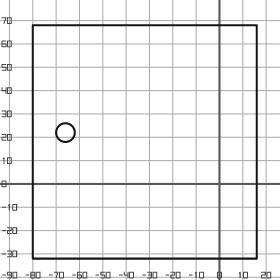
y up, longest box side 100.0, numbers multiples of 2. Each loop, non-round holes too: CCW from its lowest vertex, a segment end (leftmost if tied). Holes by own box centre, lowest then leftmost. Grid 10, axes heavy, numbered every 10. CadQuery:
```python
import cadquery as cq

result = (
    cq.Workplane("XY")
    .moveTo(-80.0, -32.0)
    .lineTo(16.0, -32.0)
    .lineTo(16.0, 68.0)
    .lineTo(-80.0, 68.0)
    .close()
    .moveTo(-66.0, 22.0)
    .circle(4.0)
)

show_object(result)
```